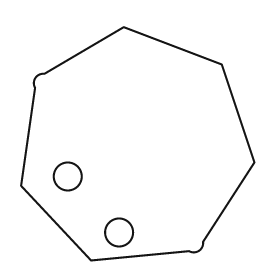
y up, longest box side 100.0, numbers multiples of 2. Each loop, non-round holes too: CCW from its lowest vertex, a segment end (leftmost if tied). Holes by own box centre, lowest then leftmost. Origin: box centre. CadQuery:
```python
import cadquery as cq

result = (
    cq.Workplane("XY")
    .moveTo(-20.0, -50.0)
    .lineTo(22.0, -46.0)
    .threePointArc((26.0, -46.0), (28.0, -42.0))
    .lineTo(50.0, -8.0)
    .lineTo(36.0, 34.0)
    .lineTo(-6.0, 50.0)
    .lineTo(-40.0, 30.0)
    .threePointArc((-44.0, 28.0), (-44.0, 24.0))
    .lineTo(-50.0, -18.0)
    .close()
    .moveTo(-8.0, -38.0)
    .circle(6.0)
    .moveTo(-30.0, -14.0)
    .circle(6.0)
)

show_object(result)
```